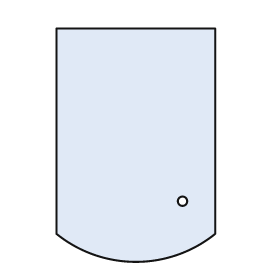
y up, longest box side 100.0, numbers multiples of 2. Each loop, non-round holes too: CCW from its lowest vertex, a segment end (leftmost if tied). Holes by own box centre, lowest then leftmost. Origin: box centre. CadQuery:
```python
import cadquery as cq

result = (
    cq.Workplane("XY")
    .moveTo(-34.0, -38.0)
    .threePointArc((0.0, -50.0), (34.0, -38.0))
    .lineTo(34.0, 50.0)
    .lineTo(-34.0, 50.0)
    .close()
    .moveTo(20.0, -24.0)
    .circle(2.0)
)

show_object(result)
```